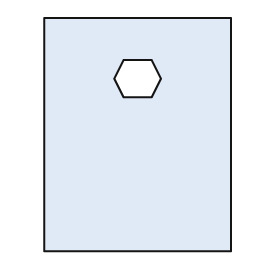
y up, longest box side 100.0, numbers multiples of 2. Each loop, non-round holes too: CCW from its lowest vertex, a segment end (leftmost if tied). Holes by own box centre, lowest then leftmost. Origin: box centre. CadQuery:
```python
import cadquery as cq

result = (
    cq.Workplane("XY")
    .moveTo(-40.0, -50.0)
    .lineTo(40.0, -50.0)
    .lineTo(40.0, 50.0)
    .lineTo(-40.0, 50.0)
    .close()
    .moveTo(-6.0, 16.0)
    .lineTo(6.0, 16.0)
    .lineTo(10.0, 24.0)
    .lineTo(6.0, 32.0)
    .lineTo(-6.0, 32.0)
    .lineTo(-10.0, 24.0)
    .close()
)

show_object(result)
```